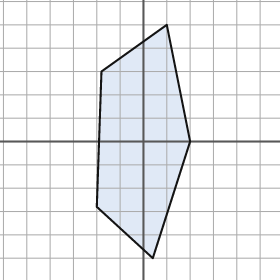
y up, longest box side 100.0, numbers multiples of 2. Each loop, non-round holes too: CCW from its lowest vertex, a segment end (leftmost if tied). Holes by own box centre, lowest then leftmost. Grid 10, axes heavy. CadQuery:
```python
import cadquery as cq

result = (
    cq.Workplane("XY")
    .moveTo(4.0, -50.0)
    .lineTo(20.0, 0.0)
    .lineTo(10.0, 50.0)
    .lineTo(-18.0, 30.0)
    .lineTo(-20.0, -28.0)
    .close()
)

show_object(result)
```